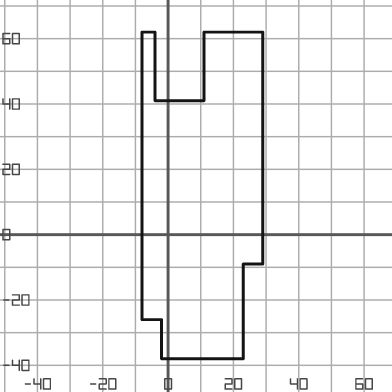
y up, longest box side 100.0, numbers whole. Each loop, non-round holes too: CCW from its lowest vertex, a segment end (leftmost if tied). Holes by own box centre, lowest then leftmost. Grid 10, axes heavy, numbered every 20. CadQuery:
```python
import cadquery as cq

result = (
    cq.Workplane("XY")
    .moveTo(-2.0, -38.0)
    .lineTo(23.0, -38.0)
    .lineTo(23.0, -9.0)
    .lineTo(29.0, -9.0)
    .lineTo(29.0, 62.0)
    .lineTo(11.0, 62.0)
    .lineTo(11.0, 41.0)
    .lineTo(-4.0, 41.0)
    .lineTo(-4.0, 62.0)
    .lineTo(-8.0, 62.0)
    .lineTo(-8.0, -26.0)
    .lineTo(-2.0, -26.0)
    .close()
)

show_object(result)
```